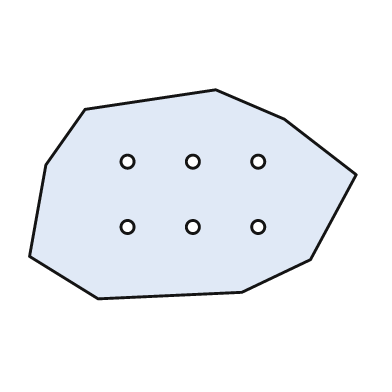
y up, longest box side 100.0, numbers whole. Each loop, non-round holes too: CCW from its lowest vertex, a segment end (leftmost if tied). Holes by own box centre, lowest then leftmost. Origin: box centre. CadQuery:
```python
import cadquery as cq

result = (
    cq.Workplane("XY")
    .moveTo(-29.0, -32.0)
    .lineTo(15.0, -30.0)
    .lineTo(36.0, -20.0)
    .lineTo(50.0, 6.0)
    .lineTo(28.0, 23.0)
    .lineTo(7.0, 32.0)
    .lineTo(-33.0, 26.0)
    .lineTo(-45.0, 9.0)
    .lineTo(-50.0, -19.0)
    .close()
    .moveTo(-20.0, -10.0)
    .circle(2.0)
    .moveTo(0.0, -10.0)
    .circle(2.0)
    .moveTo(20.0, -10.0)
    .circle(2.0)
    .moveTo(-20.0, 10.0)
    .circle(2.0)
    .moveTo(0.0, 10.0)
    .circle(2.0)
    .moveTo(20.0, 10.0)
    .circle(2.0)
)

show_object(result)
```